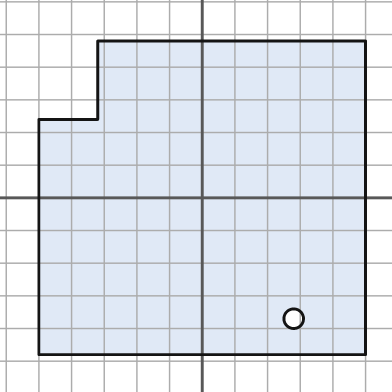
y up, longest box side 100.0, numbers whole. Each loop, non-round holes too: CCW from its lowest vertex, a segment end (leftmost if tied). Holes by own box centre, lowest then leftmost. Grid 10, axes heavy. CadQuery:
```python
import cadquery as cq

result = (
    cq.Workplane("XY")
    .moveTo(-50.0, -48.0)
    .lineTo(50.0, -48.0)
    .lineTo(50.0, 48.0)
    .lineTo(-32.0, 48.0)
    .lineTo(-32.0, 24.0)
    .lineTo(-50.0, 24.0)
    .close()
    .moveTo(28.0, -37.0)
    .circle(3.0)
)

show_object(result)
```